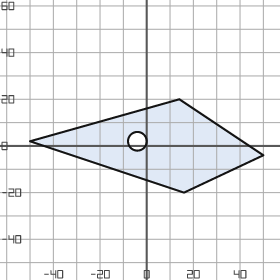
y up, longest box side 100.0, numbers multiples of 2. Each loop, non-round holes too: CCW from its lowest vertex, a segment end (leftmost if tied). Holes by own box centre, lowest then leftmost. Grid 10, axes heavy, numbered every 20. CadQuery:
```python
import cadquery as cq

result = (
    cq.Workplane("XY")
    .moveTo(16.0, -20.0)
    .lineTo(50.0, -4.0)
    .lineTo(14.0, 20.0)
    .lineTo(-50.0, 2.0)
    .close()
    .moveTo(-4.0, 2.0)
    .circle(4.0)
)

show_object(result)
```